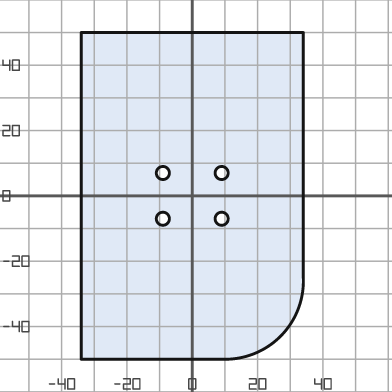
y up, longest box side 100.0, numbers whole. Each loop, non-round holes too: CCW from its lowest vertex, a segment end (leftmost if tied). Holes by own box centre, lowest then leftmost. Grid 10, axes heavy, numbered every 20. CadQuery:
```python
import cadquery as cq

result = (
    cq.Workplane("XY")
    .moveTo(-34.0, -50.0)
    .lineTo(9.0, -50.0)
    .threePointArc((27.0, -43.0), (34.0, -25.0))
    .lineTo(34.0, 50.0)
    .lineTo(-34.0, 50.0)
    .close()
    .moveTo(-9.0, -7.0)
    .circle(2.0)
    .moveTo(9.0, -7.0)
    .circle(2.0)
    .moveTo(-9.0, 7.0)
    .circle(2.0)
    .moveTo(9.0, 7.0)
    .circle(2.0)
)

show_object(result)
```